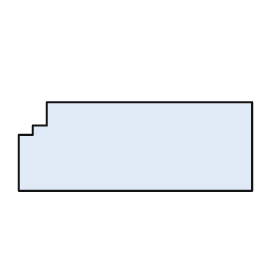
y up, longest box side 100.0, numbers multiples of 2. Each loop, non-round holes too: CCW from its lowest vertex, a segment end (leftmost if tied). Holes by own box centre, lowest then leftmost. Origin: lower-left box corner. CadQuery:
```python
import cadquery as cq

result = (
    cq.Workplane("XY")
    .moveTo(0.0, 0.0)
    .lineTo(100.0, 0.0)
    .lineTo(100.0, 38.0)
    .lineTo(12.0, 38.0)
    .lineTo(12.0, 28.0)
    .lineTo(6.0, 28.0)
    .lineTo(6.0, 24.0)
    .lineTo(0.0, 24.0)
    .close()
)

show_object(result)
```